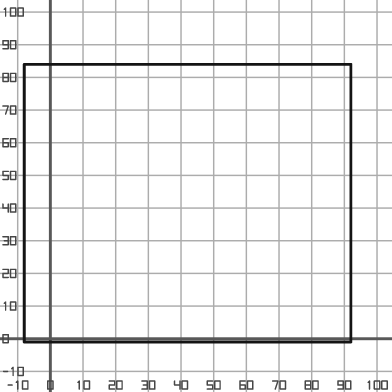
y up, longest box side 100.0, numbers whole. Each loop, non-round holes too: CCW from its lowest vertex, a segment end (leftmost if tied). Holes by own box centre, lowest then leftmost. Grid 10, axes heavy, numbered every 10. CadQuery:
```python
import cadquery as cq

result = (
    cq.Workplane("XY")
    .moveTo(-8.0, -1.0)
    .lineTo(92.0, -1.0)
    .lineTo(92.0, 84.0)
    .lineTo(-8.0, 84.0)
    .close()
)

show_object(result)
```